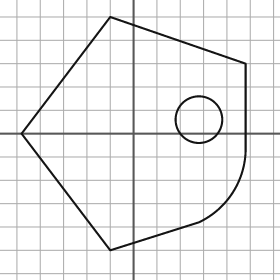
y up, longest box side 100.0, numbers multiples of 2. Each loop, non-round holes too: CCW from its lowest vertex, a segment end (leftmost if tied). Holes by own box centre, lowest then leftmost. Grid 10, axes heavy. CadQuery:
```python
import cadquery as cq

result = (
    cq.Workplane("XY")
    .moveTo(-10.0, -50.0)
    .lineTo(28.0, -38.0)
    .threePointArc((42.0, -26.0), (48.0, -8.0))
    .lineTo(48.0, 30.0)
    .lineTo(-10.0, 50.0)
    .lineTo(-48.0, 0.0)
    .close()
    .moveTo(28.0, 6.0)
    .circle(10.0)
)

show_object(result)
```